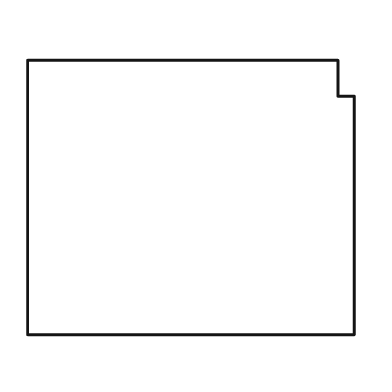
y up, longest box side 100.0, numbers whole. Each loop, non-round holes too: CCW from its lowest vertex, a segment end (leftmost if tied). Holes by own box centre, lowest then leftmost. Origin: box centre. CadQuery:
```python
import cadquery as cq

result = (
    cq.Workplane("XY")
    .moveTo(-50.0, -42.0)
    .lineTo(50.0, -42.0)
    .lineTo(50.0, 31.0)
    .lineTo(45.0, 31.0)
    .lineTo(45.0, 42.0)
    .lineTo(-50.0, 42.0)
    .close()
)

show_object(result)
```